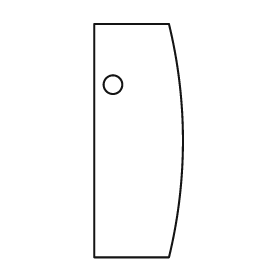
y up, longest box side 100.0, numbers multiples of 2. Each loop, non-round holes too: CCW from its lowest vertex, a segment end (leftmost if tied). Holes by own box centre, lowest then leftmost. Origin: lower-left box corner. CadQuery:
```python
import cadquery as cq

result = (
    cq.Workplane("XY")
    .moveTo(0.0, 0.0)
    .lineTo(32.0, 0.0)
    .threePointArc((38.0, 50.0), (32.0, 100.0))
    .lineTo(0.0, 100.0)
    .close()
    .moveTo(8.0, 74.0)
    .circle(4.0)
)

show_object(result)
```